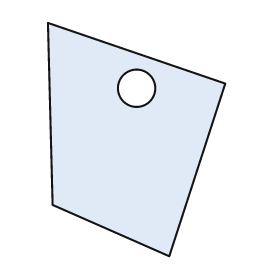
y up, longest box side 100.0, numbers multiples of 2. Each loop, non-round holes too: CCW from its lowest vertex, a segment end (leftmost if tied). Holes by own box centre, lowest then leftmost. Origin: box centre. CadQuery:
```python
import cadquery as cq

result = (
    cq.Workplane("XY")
    .moveTo(14.0, -50.0)
    .lineTo(38.0, 24.0)
    .lineTo(-38.0, 50.0)
    .lineTo(-36.0, -28.0)
    .close()
    .moveTo(0.0, 22.0)
    .circle(8.0)
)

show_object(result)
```